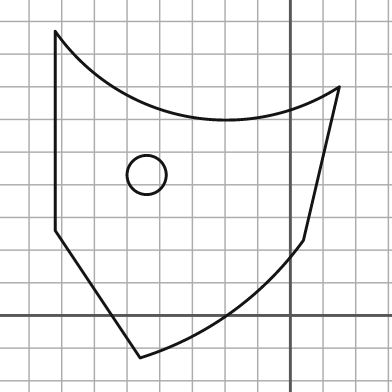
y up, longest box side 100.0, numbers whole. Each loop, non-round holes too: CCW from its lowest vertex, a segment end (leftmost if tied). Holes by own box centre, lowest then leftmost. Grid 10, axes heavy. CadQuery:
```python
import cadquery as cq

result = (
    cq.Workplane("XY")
    .moveTo(-46.0, -13.0)
    .threePointArc((-18.0, 1.0), (4.0, 23.0))
    .lineTo(15.0, 70.0)
    .threePointArc((-32.0, 61.0), (-72.0, 87.0))
    .lineTo(-72.0, 26.0)
    .close()
    .moveTo(-44.0, 43.0)
    .circle(6.0)
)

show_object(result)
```